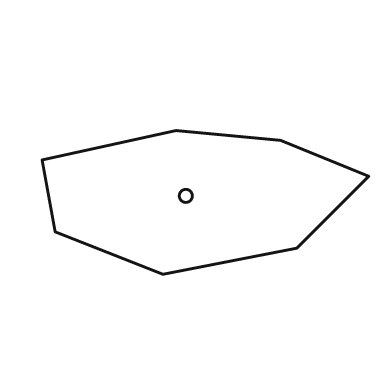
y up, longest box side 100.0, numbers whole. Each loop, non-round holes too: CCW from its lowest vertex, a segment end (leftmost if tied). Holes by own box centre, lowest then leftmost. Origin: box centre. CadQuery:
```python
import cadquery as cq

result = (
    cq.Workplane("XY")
    .moveTo(-13.0, -22.0)
    .lineTo(28.0, -14.0)
    .lineTo(50.0, 8.0)
    .lineTo(23.0, 19.0)
    .lineTo(-9.0, 22.0)
    .lineTo(-50.0, 13.0)
    .lineTo(-46.0, -9.0)
    .close()
    .moveTo(-6.0, 2.0)
    .circle(2.0)
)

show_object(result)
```